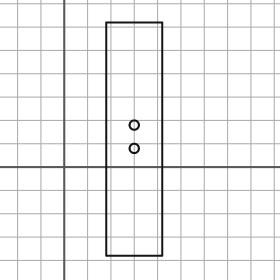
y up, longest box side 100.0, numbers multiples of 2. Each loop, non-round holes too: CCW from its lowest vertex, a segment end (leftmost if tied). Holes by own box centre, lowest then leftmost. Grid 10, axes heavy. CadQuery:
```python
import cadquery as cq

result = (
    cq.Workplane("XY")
    .moveTo(18.0, -38.0)
    .lineTo(42.0, -38.0)
    .lineTo(42.0, 62.0)
    .lineTo(18.0, 62.0)
    .close()
    .moveTo(30.0, 8.0)
    .circle(2.0)
    .moveTo(30.0, 18.0)
    .circle(2.0)
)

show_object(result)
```